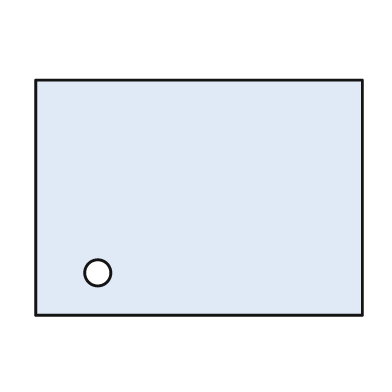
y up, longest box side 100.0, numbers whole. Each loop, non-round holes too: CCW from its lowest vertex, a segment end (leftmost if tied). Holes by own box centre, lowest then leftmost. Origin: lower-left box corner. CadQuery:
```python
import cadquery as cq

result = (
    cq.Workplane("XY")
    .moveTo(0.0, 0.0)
    .lineTo(100.0, 0.0)
    .lineTo(100.0, 72.0)
    .lineTo(0.0, 72.0)
    .close()
    .moveTo(19.0, 13.0)
    .circle(4.0)
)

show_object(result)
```